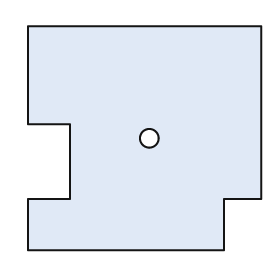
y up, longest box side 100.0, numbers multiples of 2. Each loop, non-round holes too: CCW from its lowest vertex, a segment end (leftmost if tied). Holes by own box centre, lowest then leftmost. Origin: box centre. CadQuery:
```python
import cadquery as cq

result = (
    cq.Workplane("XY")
    .moveTo(-50.0, -48.0)
    .lineTo(34.0, -48.0)
    .lineTo(34.0, -26.0)
    .lineTo(50.0, -26.0)
    .lineTo(50.0, 48.0)
    .lineTo(-50.0, 48.0)
    .lineTo(-50.0, 6.0)
    .lineTo(-32.0, 6.0)
    .lineTo(-32.0, -26.0)
    .lineTo(-50.0, -26.0)
    .close()
    .moveTo(2.0, 0.0)
    .circle(4.0)
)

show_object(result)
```